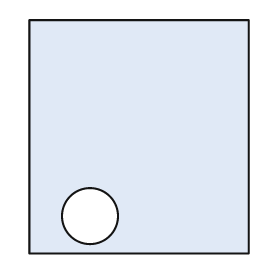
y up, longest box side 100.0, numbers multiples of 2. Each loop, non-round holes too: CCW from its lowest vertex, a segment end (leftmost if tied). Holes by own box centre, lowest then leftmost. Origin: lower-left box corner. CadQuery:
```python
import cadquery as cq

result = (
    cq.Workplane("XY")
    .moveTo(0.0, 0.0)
    .lineTo(94.0, 0.0)
    .lineTo(94.0, 100.0)
    .lineTo(0.0, 100.0)
    .close()
    .moveTo(26.0, 16.0)
    .circle(12.0)
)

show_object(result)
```